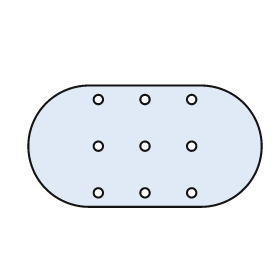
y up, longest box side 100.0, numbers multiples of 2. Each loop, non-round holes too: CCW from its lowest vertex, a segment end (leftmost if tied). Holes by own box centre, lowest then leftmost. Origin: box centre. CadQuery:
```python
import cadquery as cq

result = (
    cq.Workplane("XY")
    .moveTo(-24.0, -26.0)
    .lineTo(24.0, -26.0)
    .threePointArc((50.0, 0.0), (24.0, 26.0))
    .lineTo(-24.0, 26.0)
    .threePointArc((-50.0, 0.0), (-24.0, -26.0))
    .close()
    .moveTo(-20.0, -20.0)
    .circle(2.0)
    .moveTo(0.0, -20.0)
    .circle(2.0)
    .moveTo(20.0, -20.0)
    .circle(2.0)
    .moveTo(-20.0, 0.0)
    .circle(2.0)
    .moveTo(0.0, 0.0)
    .circle(2.0)
    .moveTo(20.0, 0.0)
    .circle(2.0)
    .moveTo(-20.0, 20.0)
    .circle(2.0)
    .moveTo(0.0, 20.0)
    .circle(2.0)
    .moveTo(20.0, 20.0)
    .circle(2.0)
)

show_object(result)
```